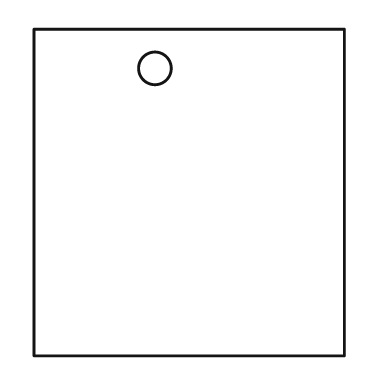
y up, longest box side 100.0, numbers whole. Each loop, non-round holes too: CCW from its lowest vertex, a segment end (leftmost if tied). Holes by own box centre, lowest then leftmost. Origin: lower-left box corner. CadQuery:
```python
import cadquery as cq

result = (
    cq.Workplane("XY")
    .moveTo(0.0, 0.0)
    .lineTo(95.0, 0.0)
    .lineTo(95.0, 100.0)
    .lineTo(0.0, 100.0)
    .close()
    .moveTo(37.0, 88.0)
    .circle(5.0)
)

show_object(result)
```